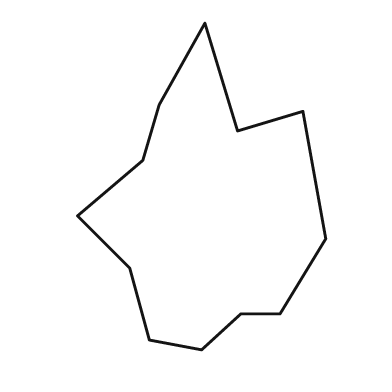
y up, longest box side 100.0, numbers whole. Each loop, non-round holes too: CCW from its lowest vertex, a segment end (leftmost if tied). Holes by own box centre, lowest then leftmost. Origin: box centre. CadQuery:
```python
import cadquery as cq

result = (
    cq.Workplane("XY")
    .moveTo(0.0, -50.0)
    .lineTo(12.0, -39.0)
    .lineTo(24.0, -39.0)
    .lineTo(38.0, -16.0)
    .lineTo(31.0, 23.0)
    .lineTo(11.0, 17.0)
    .lineTo(1.0, 50.0)
    .lineTo(-13.0, 25.0)
    .lineTo(-18.0, 8.0)
    .lineTo(-38.0, -9.0)
    .lineTo(-22.0, -25.0)
    .lineTo(-16.0, -47.0)
    .close()
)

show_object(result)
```